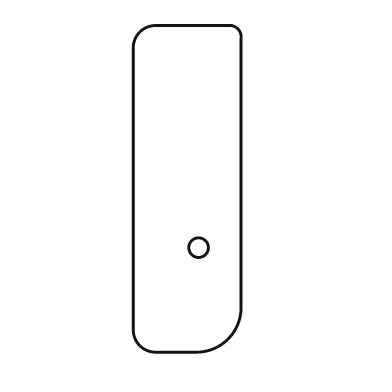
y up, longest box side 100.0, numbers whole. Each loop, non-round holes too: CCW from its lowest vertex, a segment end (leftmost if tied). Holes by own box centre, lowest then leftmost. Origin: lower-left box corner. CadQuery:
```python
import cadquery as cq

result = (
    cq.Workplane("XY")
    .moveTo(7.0, 0.0)
    .lineTo(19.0, 0.0)
    .threePointArc((29.0, 4.0), (33.0, 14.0))
    .lineTo(33.0, 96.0)
    .threePointArc((32.0, 99.0), (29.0, 100.0))
    .lineTo(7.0, 100.0)
    .threePointArc((2.0, 98.0), (0.0, 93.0))
    .lineTo(0.0, 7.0)
    .threePointArc((2.0, 2.0), (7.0, 0.0))
    .close()
    .moveTo(20.0, 32.0)
    .circle(3.0)
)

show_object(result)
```